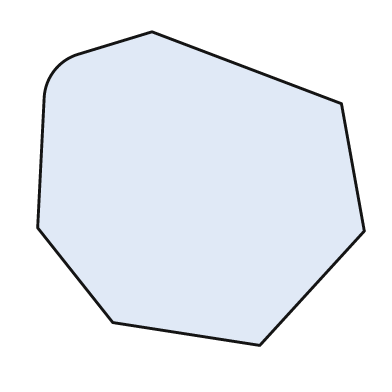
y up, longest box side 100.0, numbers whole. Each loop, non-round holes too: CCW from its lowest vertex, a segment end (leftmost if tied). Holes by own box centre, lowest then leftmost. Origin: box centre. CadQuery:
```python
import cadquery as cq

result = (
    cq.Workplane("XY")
    .moveTo(18.0, -48.0)
    .lineTo(50.0, -13.0)
    .lineTo(43.0, 26.0)
    .lineTo(-15.0, 48.0)
    .lineTo(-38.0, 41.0)
    .threePointArc((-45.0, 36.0), (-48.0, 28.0))
    .lineTo(-50.0, -12.0)
    .lineTo(-27.0, -41.0)
    .close()
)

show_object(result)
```